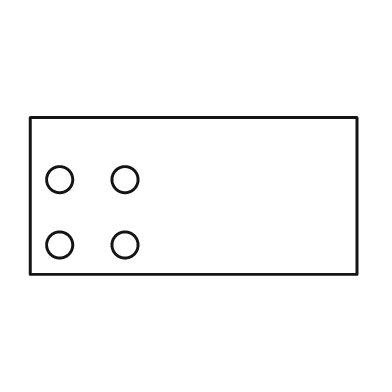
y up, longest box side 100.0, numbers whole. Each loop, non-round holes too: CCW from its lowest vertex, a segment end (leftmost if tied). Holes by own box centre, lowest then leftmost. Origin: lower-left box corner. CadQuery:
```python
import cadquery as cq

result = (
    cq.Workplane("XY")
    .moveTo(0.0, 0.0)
    .lineTo(100.0, 0.0)
    .lineTo(100.0, 48.0)
    .lineTo(0.0, 48.0)
    .close()
    .moveTo(9.0, 9.0)
    .circle(4.0)
    .moveTo(29.0, 9.0)
    .circle(4.0)
    .moveTo(9.0, 29.0)
    .circle(4.0)
    .moveTo(29.0, 29.0)
    .circle(4.0)
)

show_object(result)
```